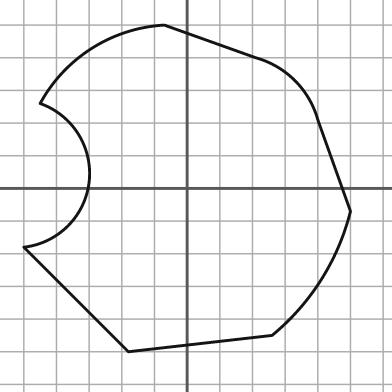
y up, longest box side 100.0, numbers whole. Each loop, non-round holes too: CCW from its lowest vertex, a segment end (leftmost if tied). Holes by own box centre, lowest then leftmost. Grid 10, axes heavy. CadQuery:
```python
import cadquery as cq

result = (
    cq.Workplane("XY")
    .moveTo(-18.0, -50.0)
    .lineTo(26.0, -45.0)
    .threePointArc((41.0, -28.0), (50.0, -7.0))
    .lineTo(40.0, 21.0)
    .threePointArc((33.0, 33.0), (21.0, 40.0))
    .lineTo(-7.0, 50.0)
    .threePointArc((-29.0, 43.0), (-45.0, 26.0))
    .threePointArc((-30.0, 2.0), (-50.0, -18.0))
    .close()
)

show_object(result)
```